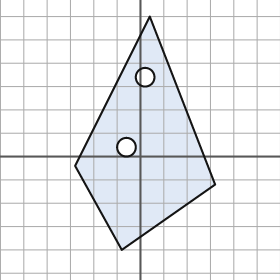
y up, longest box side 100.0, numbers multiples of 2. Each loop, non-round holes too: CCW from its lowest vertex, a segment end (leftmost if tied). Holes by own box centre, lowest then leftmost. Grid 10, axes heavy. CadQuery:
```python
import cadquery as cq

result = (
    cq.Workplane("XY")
    .moveTo(-8.0, -40.0)
    .lineTo(32.0, -12.0)
    .lineTo(4.0, 60.0)
    .lineTo(-28.0, -4.0)
    .close()
    .moveTo(-6.0, 4.0)
    .circle(4.0)
    .moveTo(2.0, 34.0)
    .circle(4.0)
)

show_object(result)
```